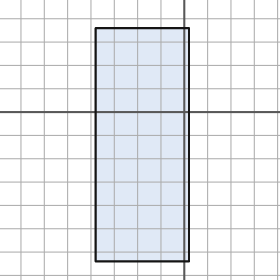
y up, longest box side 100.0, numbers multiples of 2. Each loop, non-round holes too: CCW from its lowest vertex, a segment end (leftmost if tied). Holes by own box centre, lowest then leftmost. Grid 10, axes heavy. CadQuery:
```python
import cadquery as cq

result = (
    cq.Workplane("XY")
    .moveTo(-38.0, -64.0)
    .lineTo(2.0, -64.0)
    .lineTo(2.0, 36.0)
    .lineTo(-38.0, 36.0)
    .close()
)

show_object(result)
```